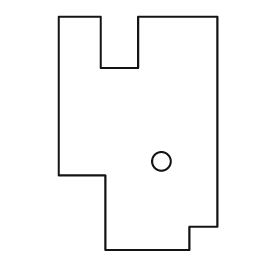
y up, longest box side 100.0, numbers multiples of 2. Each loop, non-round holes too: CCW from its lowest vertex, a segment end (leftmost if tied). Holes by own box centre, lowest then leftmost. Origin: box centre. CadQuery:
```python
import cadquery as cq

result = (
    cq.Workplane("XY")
    .moveTo(-14.0, -50.0)
    .lineTo(22.0, -50.0)
    .lineTo(22.0, -40.0)
    .lineTo(34.0, -40.0)
    .lineTo(34.0, 50.0)
    .lineTo(0.0, 50.0)
    .lineTo(0.0, 28.0)
    .lineTo(-16.0, 28.0)
    .lineTo(-16.0, 50.0)
    .lineTo(-34.0, 50.0)
    .lineTo(-34.0, -18.0)
    .lineTo(-14.0, -18.0)
    .close()
    .moveTo(10.0, -12.0)
    .circle(4.0)
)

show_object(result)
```